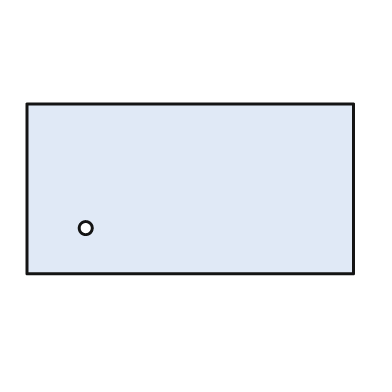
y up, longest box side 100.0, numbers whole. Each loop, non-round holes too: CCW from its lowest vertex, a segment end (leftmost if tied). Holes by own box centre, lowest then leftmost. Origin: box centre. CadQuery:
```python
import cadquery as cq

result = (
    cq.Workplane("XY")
    .moveTo(-50.0, -26.0)
    .lineTo(50.0, -26.0)
    .lineTo(50.0, 26.0)
    .lineTo(-50.0, 26.0)
    .close()
    .moveTo(-32.0, -12.0)
    .circle(2.0)
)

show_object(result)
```